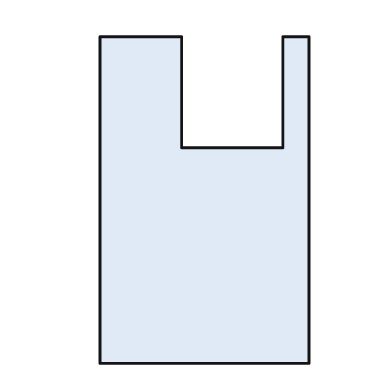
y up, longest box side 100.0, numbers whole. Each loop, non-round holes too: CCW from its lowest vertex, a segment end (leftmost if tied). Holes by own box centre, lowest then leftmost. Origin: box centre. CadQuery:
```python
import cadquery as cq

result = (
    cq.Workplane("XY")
    .moveTo(-32.0, -50.0)
    .lineTo(32.0, -50.0)
    .lineTo(32.0, 50.0)
    .lineTo(24.0, 50.0)
    .lineTo(24.0, 16.0)
    .lineTo(-7.0, 16.0)
    .lineTo(-7.0, 50.0)
    .lineTo(-32.0, 50.0)
    .close()
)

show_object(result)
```